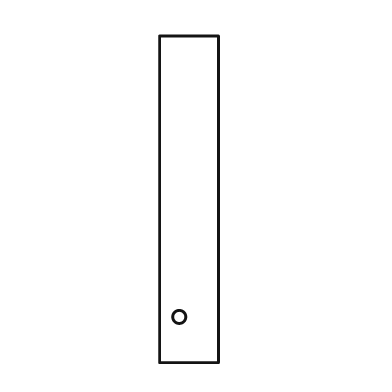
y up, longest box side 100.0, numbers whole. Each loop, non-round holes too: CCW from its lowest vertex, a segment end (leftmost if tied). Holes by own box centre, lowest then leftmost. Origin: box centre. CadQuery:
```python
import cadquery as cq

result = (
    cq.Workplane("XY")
    .moveTo(-9.0, -50.0)
    .lineTo(9.0, -50.0)
    .lineTo(9.0, 50.0)
    .lineTo(-9.0, 50.0)
    .close()
    .moveTo(-3.0, -36.0)
    .circle(2.0)
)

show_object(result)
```